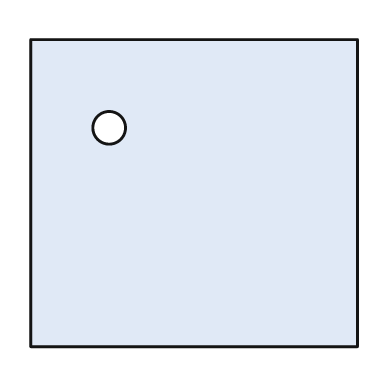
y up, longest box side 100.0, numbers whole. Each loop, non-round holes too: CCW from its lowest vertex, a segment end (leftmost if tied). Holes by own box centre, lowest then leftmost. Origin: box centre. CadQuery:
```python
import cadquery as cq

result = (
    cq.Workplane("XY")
    .moveTo(-50.0, -47.0)
    .lineTo(50.0, -47.0)
    .lineTo(50.0, 47.0)
    .lineTo(-50.0, 47.0)
    .close()
    .moveTo(-26.0, 20.0)
    .circle(5.0)
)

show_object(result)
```